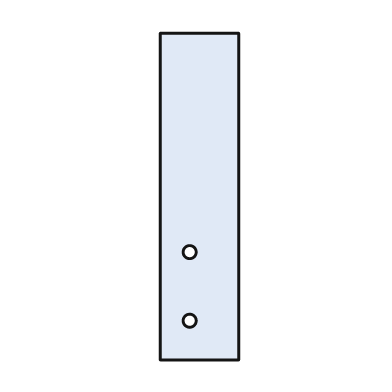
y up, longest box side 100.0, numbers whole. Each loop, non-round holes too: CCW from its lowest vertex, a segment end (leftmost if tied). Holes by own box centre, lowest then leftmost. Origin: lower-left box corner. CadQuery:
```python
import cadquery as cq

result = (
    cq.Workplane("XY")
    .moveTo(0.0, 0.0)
    .lineTo(24.0, 0.0)
    .lineTo(24.0, 100.0)
    .lineTo(0.0, 100.0)
    .close()
    .moveTo(9.0, 12.0)
    .circle(2.0)
    .moveTo(9.0, 33.0)
    .circle(2.0)
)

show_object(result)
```